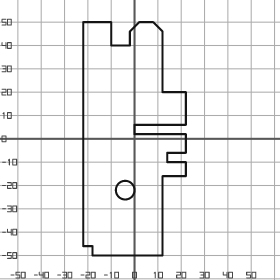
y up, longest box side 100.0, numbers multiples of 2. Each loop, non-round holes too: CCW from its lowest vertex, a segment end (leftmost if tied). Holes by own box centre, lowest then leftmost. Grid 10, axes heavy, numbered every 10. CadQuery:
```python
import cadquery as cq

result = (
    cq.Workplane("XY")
    .moveTo(-18.0, -50.0)
    .lineTo(12.0, -50.0)
    .lineTo(12.0, -16.0)
    .lineTo(22.0, -16.0)
    .lineTo(22.0, -10.0)
    .lineTo(14.0, -10.0)
    .lineTo(14.0, -6.0)
    .lineTo(22.0, -6.0)
    .lineTo(22.0, 2.0)
    .lineTo(0.0, 2.0)
    .lineTo(0.0, 6.0)
    .lineTo(22.0, 6.0)
    .lineTo(22.0, 20.0)
    .lineTo(12.0, 20.0)
    .lineTo(12.0, 46.0)
    .lineTo(8.0, 50.0)
    .lineTo(2.0, 50.0)
    .lineTo(-2.0, 46.0)
    .lineTo(-2.0, 40.0)
    .lineTo(-10.0, 40.0)
    .lineTo(-10.0, 50.0)
    .lineTo(-22.0, 50.0)
    .lineTo(-22.0, -46.0)
    .lineTo(-18.0, -46.0)
    .close()
    .moveTo(-4.0, -22.0)
    .circle(4.0)
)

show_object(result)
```